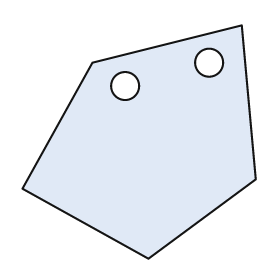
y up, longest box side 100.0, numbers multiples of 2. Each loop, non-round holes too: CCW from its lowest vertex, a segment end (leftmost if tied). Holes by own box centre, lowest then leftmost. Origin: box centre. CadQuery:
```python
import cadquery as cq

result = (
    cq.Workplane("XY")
    .moveTo(4.0, -50.0)
    .lineTo(50.0, -16.0)
    .lineTo(44.0, 50.0)
    .lineTo(-20.0, 34.0)
    .lineTo(-50.0, -20.0)
    .close()
    .moveTo(-6.0, 24.0)
    .circle(6.0)
    .moveTo(30.0, 34.0)
    .circle(6.0)
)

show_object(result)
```